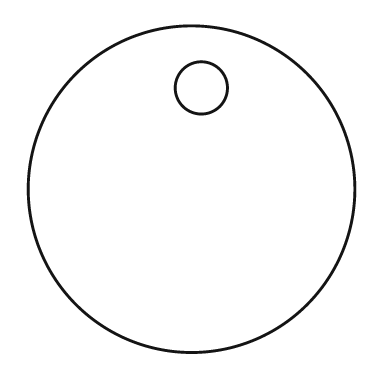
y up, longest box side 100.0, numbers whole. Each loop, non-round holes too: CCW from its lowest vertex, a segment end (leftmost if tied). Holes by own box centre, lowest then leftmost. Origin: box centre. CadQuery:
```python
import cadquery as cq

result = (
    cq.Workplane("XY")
    .moveTo(0.0, 0.0)
    .circle(50.0)
    .moveTo(3.0, 31.0)
    .circle(8.0)
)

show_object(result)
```